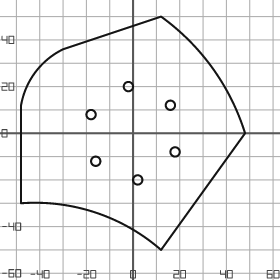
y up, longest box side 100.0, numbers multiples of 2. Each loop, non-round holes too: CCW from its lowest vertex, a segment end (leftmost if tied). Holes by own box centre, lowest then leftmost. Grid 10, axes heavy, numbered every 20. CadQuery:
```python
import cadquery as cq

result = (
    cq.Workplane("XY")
    .moveTo(12.0, -50.0)
    .lineTo(48.0, 0.0)
    .threePointArc((34.0, 28.0), (12.0, 50.0))
    .lineTo(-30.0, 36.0)
    .threePointArc((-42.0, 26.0), (-48.0, 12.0))
    .lineTo(-48.0, -30.0)
    .threePointArc((-16.0, -34.0), (12.0, -50.0))
    .close()
    .moveTo(2.0, -20.0)
    .circle(2.0)
    .moveTo(-16.0, -12.0)
    .circle(2.0)
    .moveTo(18.0, -8.0)
    .circle(2.0)
    .moveTo(-18.0, 8.0)
    .circle(2.0)
    .moveTo(16.0, 12.0)
    .circle(2.0)
    .moveTo(-2.0, 20.0)
    .circle(2.0)
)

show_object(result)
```